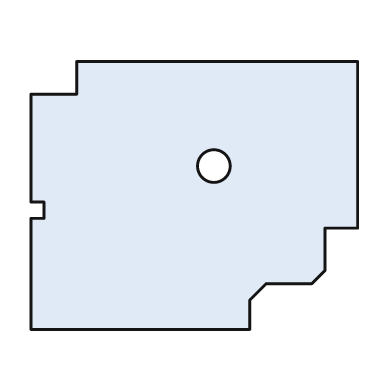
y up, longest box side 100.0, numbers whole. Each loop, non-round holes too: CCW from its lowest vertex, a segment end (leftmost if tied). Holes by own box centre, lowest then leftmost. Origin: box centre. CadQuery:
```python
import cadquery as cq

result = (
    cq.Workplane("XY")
    .moveTo(-50.0, -41.0)
    .lineTo(17.0, -41.0)
    .lineTo(17.0, -32.0)
    .lineTo(22.0, -27.0)
    .lineTo(36.0, -27.0)
    .lineTo(40.0, -23.0)
    .lineTo(40.0, -10.0)
    .lineTo(50.0, -10.0)
    .lineTo(50.0, 41.0)
    .lineTo(-36.0, 41.0)
    .lineTo(-36.0, 31.0)
    .lineTo(-50.0, 31.0)
    .lineTo(-50.0, -2.0)
    .lineTo(-46.0, -2.0)
    .lineTo(-46.0, -7.0)
    .lineTo(-50.0, -7.0)
    .close()
    .moveTo(6.0, 9.0)
    .circle(5.0)
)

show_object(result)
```